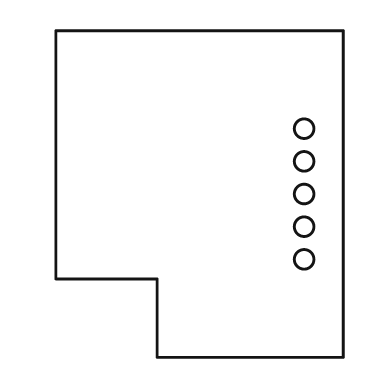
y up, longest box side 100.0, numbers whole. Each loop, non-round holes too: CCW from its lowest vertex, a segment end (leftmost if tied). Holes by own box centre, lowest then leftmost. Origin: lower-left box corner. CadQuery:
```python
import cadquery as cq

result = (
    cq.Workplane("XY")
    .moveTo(31.0, 0.0)
    .lineTo(88.0, 0.0)
    .lineTo(88.0, 100.0)
    .lineTo(0.0, 100.0)
    .lineTo(0.0, 24.0)
    .lineTo(31.0, 24.0)
    .close()
    .moveTo(76.0, 30.0)
    .circle(3.0)
    .moveTo(76.0, 40.0)
    .circle(3.0)
    .moveTo(76.0, 50.0)
    .circle(3.0)
    .moveTo(76.0, 60.0)
    .circle(3.0)
    .moveTo(76.0, 70.0)
    .circle(3.0)
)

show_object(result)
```